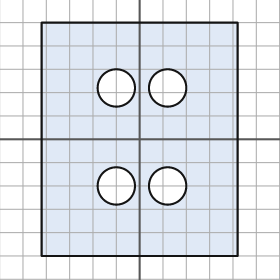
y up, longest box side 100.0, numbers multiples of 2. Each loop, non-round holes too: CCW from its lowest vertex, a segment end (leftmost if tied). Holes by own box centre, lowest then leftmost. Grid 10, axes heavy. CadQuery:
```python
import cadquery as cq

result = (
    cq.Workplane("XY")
    .moveTo(-42.0, -50.0)
    .lineTo(42.0, -50.0)
    .lineTo(42.0, 50.0)
    .lineTo(-42.0, 50.0)
    .close()
    .moveTo(-10.0, -20.0)
    .circle(8.0)
    .moveTo(12.0, -20.0)
    .circle(8.0)
    .moveTo(-10.0, 22.0)
    .circle(8.0)
    .moveTo(12.0, 22.0)
    .circle(8.0)
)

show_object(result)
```